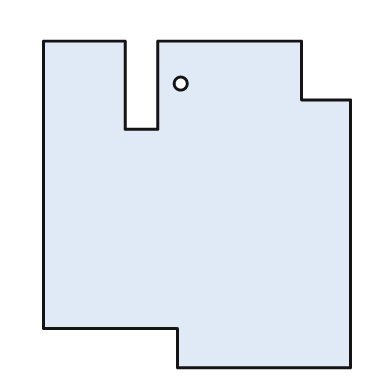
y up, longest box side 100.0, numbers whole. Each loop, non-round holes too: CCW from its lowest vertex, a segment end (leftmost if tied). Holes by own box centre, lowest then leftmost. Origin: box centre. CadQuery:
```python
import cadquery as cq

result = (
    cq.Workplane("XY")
    .moveTo(-6.0, -50.0)
    .lineTo(47.0, -50.0)
    .lineTo(47.0, 32.0)
    .lineTo(32.0, 32.0)
    .lineTo(32.0, 50.0)
    .lineTo(-12.0, 50.0)
    .lineTo(-12.0, 23.0)
    .lineTo(-22.0, 23.0)
    .lineTo(-22.0, 50.0)
    .lineTo(-47.0, 50.0)
    .lineTo(-47.0, -38.0)
    .lineTo(-6.0, -38.0)
    .close()
    .moveTo(-5.0, 37.0)
    .circle(2.0)
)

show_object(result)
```